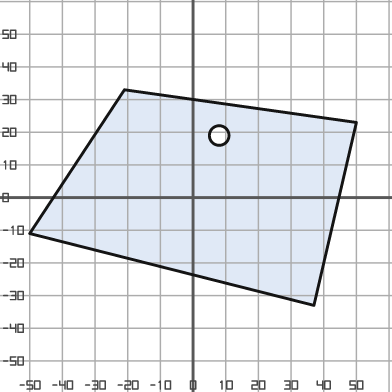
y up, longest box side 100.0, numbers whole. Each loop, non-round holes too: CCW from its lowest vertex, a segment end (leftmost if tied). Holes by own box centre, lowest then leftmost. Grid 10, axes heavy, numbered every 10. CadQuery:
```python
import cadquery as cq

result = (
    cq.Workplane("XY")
    .moveTo(37.0, -33.0)
    .lineTo(50.0, 23.0)
    .lineTo(-21.0, 33.0)
    .lineTo(-50.0, -11.0)
    .close()
    .moveTo(8.0, 19.0)
    .circle(3.0)
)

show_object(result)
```